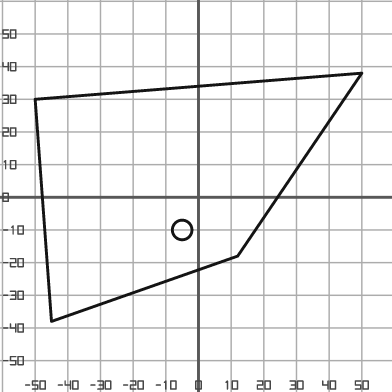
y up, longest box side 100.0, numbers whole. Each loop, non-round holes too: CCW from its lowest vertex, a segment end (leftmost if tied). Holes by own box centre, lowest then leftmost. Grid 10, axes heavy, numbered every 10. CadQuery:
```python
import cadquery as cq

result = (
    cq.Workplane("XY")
    .moveTo(-45.0, -38.0)
    .lineTo(12.0, -18.0)
    .lineTo(50.0, 38.0)
    .lineTo(-50.0, 30.0)
    .close()
    .moveTo(-5.0, -10.0)
    .circle(3.0)
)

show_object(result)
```